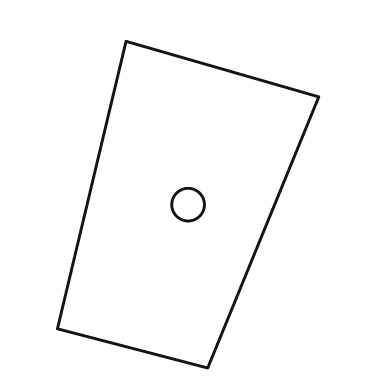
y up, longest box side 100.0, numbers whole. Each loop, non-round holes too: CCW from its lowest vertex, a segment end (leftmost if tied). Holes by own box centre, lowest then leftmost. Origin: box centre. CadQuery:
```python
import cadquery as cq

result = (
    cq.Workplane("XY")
    .moveTo(6.0, -50.0)
    .lineTo(40.0, 33.0)
    .lineTo(-19.0, 50.0)
    .lineTo(-40.0, -38.0)
    .close()
    .moveTo(0.0, 0.0)
    .circle(5.0)
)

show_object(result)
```